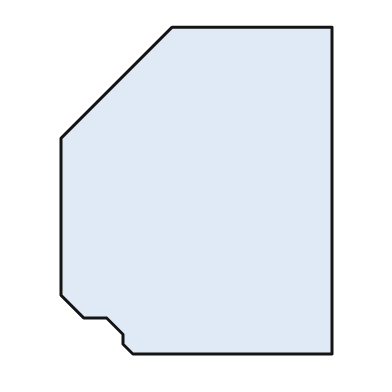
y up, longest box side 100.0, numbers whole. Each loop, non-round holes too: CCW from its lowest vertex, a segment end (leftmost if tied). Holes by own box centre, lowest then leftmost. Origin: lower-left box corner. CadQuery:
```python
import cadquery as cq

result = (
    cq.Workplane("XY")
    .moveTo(22.0, 0.0)
    .lineTo(83.0, 0.0)
    .lineTo(83.0, 100.0)
    .lineTo(34.0, 100.0)
    .lineTo(0.0, 66.0)
    .lineTo(0.0, 18.0)
    .lineTo(7.0, 11.0)
    .lineTo(14.0, 11.0)
    .lineTo(19.0, 6.0)
    .lineTo(19.0, 3.0)
    .close()
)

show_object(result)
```